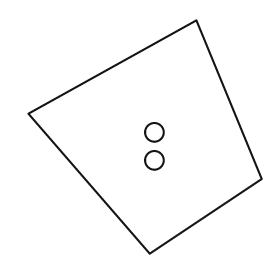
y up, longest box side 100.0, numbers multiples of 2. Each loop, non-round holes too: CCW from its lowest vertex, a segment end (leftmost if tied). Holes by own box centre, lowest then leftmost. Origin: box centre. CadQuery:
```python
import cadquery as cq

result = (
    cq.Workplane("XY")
    .moveTo(2.0, -50.0)
    .lineTo(50.0, -18.0)
    .lineTo(22.0, 50.0)
    .lineTo(-50.0, 10.0)
    .close()
    .moveTo(4.0, -10.0)
    .circle(4.0)
    .moveTo(4.0, 2.0)
    .circle(4.0)
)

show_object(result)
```